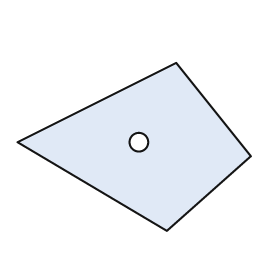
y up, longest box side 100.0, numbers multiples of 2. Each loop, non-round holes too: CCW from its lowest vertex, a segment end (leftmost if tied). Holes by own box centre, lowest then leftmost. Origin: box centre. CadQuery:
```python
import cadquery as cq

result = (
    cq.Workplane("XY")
    .moveTo(14.0, -36.0)
    .lineTo(50.0, -4.0)
    .lineTo(18.0, 36.0)
    .lineTo(-50.0, 2.0)
    .close()
    .moveTo(2.0, 2.0)
    .circle(4.0)
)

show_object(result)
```